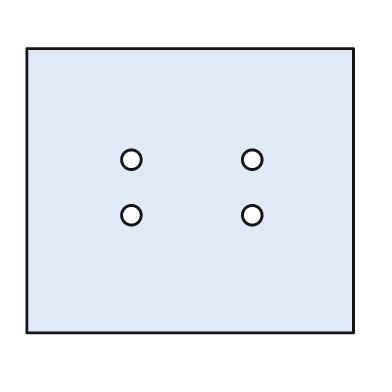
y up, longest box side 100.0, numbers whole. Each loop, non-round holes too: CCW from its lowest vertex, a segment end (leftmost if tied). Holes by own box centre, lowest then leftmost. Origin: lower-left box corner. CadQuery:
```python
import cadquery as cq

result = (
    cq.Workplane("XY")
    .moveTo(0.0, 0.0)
    .lineTo(100.0, 0.0)
    .lineTo(100.0, 87.0)
    .lineTo(0.0, 87.0)
    .close()
    .moveTo(32.0, 36.0)
    .circle(3.0)
    .moveTo(69.0, 36.0)
    .circle(3.0)
    .moveTo(32.0, 53.0)
    .circle(3.0)
    .moveTo(69.0, 53.0)
    .circle(3.0)
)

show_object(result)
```